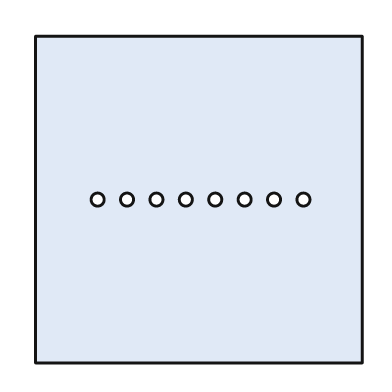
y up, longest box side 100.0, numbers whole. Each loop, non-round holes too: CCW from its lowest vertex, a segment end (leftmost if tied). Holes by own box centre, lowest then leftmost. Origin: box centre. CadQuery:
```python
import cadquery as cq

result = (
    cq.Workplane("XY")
    .moveTo(-50.0, -50.0)
    .lineTo(50.0, -50.0)
    .lineTo(50.0, 50.0)
    .lineTo(-50.0, 50.0)
    .close()
    .moveTo(-31.0, 0.0)
    .circle(2.0)
    .moveTo(-22.0, 0.0)
    .circle(2.0)
    .moveTo(-13.0, 0.0)
    .circle(2.0)
    .moveTo(-4.0, 0.0)
    .circle(2.0)
    .moveTo(5.0, 0.0)
    .circle(2.0)
    .moveTo(14.0, 0.0)
    .circle(2.0)
    .moveTo(23.0, 0.0)
    .circle(2.0)
    .moveTo(32.0, 0.0)
    .circle(2.0)
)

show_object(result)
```